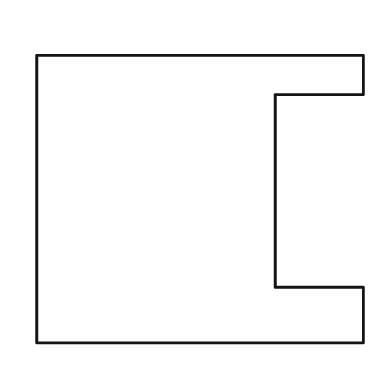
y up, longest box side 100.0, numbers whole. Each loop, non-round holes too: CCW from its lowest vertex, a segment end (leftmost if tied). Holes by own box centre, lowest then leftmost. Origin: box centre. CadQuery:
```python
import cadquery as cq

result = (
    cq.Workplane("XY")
    .moveTo(-50.0, -44.0)
    .lineTo(50.0, -44.0)
    .lineTo(50.0, -27.0)
    .lineTo(23.0, -27.0)
    .lineTo(23.0, 32.0)
    .lineTo(50.0, 32.0)
    .lineTo(50.0, 44.0)
    .lineTo(-50.0, 44.0)
    .close()
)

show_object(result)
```